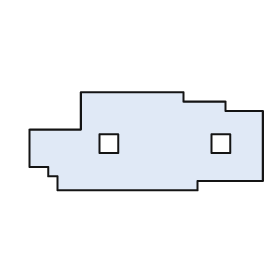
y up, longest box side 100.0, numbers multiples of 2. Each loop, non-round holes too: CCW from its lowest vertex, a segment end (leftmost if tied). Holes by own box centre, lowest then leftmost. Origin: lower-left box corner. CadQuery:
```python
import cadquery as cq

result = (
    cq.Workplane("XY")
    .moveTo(12.0, 0.0)
    .lineTo(72.0, 0.0)
    .lineTo(72.0, 4.0)
    .lineTo(100.0, 4.0)
    .lineTo(100.0, 34.0)
    .lineTo(84.0, 34.0)
    .lineTo(84.0, 38.0)
    .lineTo(66.0, 38.0)
    .lineTo(66.0, 42.0)
    .lineTo(22.0, 42.0)
    .lineTo(22.0, 26.0)
    .lineTo(0.0, 26.0)
    .lineTo(0.0, 10.0)
    .lineTo(8.0, 10.0)
    .lineTo(8.0, 6.0)
    .lineTo(12.0, 6.0)
    .close()
    .moveTo(30.0, 16.0)
    .lineTo(38.0, 16.0)
    .lineTo(38.0, 24.0)
    .lineTo(30.0, 24.0)
    .close()
    .moveTo(78.0, 16.0)
    .lineTo(86.0, 16.0)
    .lineTo(86.0, 24.0)
    .lineTo(78.0, 24.0)
    .close()
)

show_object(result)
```